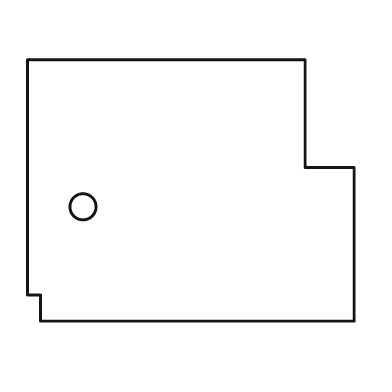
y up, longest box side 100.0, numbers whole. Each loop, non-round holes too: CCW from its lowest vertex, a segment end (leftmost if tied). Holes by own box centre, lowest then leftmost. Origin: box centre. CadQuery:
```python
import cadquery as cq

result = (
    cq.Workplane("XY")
    .moveTo(-46.0, -40.0)
    .lineTo(50.0, -40.0)
    .lineTo(50.0, 7.0)
    .lineTo(35.0, 7.0)
    .lineTo(35.0, 40.0)
    .lineTo(-50.0, 40.0)
    .lineTo(-50.0, -32.0)
    .lineTo(-46.0, -32.0)
    .close()
    .moveTo(-33.0, -5.0)
    .circle(4.0)
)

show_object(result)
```